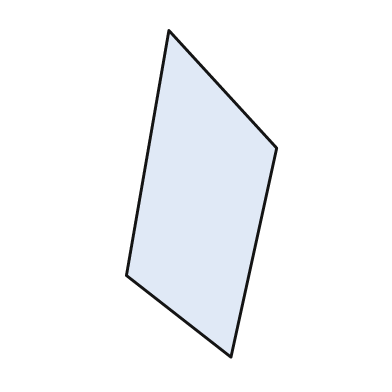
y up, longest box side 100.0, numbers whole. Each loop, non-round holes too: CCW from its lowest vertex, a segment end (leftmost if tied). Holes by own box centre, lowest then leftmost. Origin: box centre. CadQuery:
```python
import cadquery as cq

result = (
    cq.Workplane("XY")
    .moveTo(9.0, -50.0)
    .lineTo(23.0, 14.0)
    .lineTo(-10.0, 50.0)
    .lineTo(-23.0, -25.0)
    .close()
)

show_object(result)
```